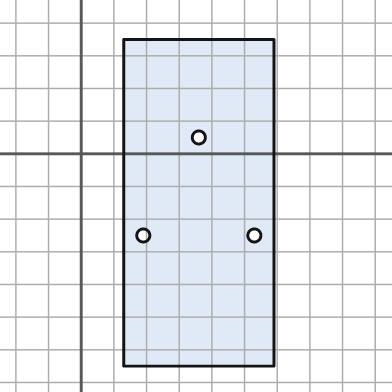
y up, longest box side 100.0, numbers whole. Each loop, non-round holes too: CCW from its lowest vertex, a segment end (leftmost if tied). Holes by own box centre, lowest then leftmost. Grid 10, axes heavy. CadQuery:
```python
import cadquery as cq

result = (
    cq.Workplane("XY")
    .moveTo(13.0, -65.0)
    .lineTo(59.0, -65.0)
    .lineTo(59.0, 35.0)
    .lineTo(13.0, 35.0)
    .close()
    .moveTo(19.0, -25.0)
    .circle(2.0)
    .moveTo(53.0, -25.0)
    .circle(2.0)
    .moveTo(36.0, 5.0)
    .circle(2.0)
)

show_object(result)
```